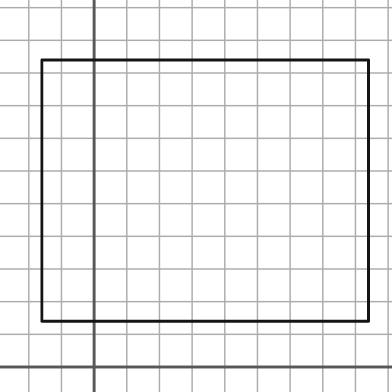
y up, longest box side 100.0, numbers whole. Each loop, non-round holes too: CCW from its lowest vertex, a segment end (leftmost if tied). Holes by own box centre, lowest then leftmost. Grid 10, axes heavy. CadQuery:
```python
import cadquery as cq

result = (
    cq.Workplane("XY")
    .moveTo(-16.0, 14.0)
    .lineTo(84.0, 14.0)
    .lineTo(84.0, 94.0)
    .lineTo(-16.0, 94.0)
    .close()
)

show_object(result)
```